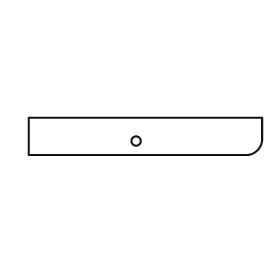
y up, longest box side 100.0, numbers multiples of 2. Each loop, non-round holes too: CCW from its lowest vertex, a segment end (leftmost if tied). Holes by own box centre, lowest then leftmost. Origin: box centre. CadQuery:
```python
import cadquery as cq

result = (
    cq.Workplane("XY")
    .moveTo(-50.0, -8.0)
    .lineTo(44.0, -8.0)
    .threePointArc((48.0, -6.0), (50.0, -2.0))
    .lineTo(50.0, 8.0)
    .lineTo(-50.0, 8.0)
    .close()
    .moveTo(-4.0, -2.0)
    .circle(2.0)
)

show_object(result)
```